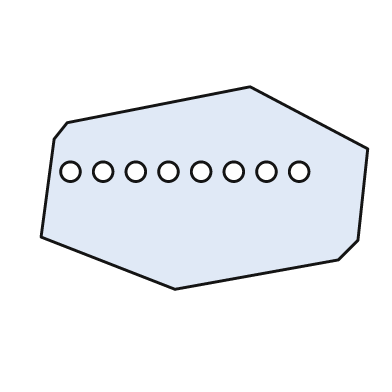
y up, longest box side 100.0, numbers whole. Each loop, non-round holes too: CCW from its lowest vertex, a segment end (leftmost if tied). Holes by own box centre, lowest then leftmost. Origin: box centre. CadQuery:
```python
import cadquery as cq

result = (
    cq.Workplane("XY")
    .moveTo(-9.0, -31.0)
    .lineTo(41.0, -22.0)
    .lineTo(47.0, -16.0)
    .lineTo(50.0, 12.0)
    .lineTo(14.0, 31.0)
    .lineTo(-42.0, 20.0)
    .lineTo(-46.0, 15.0)
    .lineTo(-50.0, -15.0)
    .close()
    .moveTo(-41.0, 5.0)
    .circle(3.0)
    .moveTo(-31.0, 5.0)
    .circle(3.0)
    .moveTo(-21.0, 5.0)
    .circle(3.0)
    .moveTo(-11.0, 5.0)
    .circle(3.0)
    .moveTo(-1.0, 5.0)
    .circle(3.0)
    .moveTo(9.0, 5.0)
    .circle(3.0)
    .moveTo(19.0, 5.0)
    .circle(3.0)
    .moveTo(29.0, 5.0)
    .circle(3.0)
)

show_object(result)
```